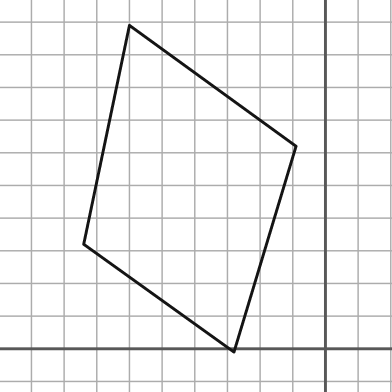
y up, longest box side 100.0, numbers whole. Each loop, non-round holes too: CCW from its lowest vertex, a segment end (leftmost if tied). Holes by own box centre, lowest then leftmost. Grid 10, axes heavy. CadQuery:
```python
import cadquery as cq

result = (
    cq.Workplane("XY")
    .moveTo(-28.0, -1.0)
    .lineTo(-9.0, 62.0)
    .lineTo(-60.0, 99.0)
    .lineTo(-74.0, 32.0)
    .close()
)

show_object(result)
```